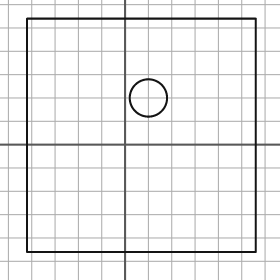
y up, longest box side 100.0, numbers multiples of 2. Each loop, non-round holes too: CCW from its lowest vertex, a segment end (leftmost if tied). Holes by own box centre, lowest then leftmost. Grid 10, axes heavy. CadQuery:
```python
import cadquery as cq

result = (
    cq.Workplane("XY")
    .moveTo(-42.0, -46.0)
    .lineTo(56.0, -46.0)
    .lineTo(56.0, 54.0)
    .lineTo(-42.0, 54.0)
    .close()
    .moveTo(10.0, 20.0)
    .circle(8.0)
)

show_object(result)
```